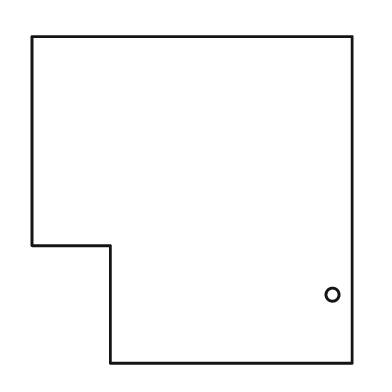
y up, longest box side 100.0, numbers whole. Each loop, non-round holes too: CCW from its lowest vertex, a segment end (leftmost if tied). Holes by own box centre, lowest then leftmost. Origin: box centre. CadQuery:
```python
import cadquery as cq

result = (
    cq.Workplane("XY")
    .moveTo(-25.0, -50.0)
    .lineTo(49.0, -50.0)
    .lineTo(49.0, 50.0)
    .lineTo(-49.0, 50.0)
    .lineTo(-49.0, -14.0)
    .lineTo(-25.0, -14.0)
    .close()
    .moveTo(43.0, -29.0)
    .circle(2.0)
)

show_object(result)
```